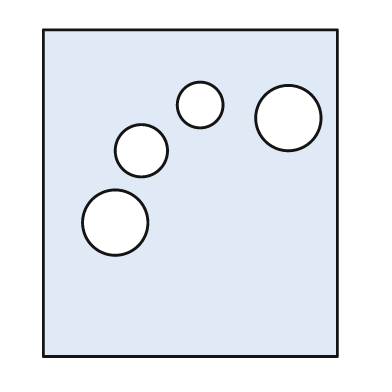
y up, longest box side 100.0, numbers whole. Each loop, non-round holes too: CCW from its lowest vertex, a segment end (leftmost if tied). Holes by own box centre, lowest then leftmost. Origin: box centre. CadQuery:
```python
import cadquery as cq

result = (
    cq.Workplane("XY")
    .moveTo(-45.0, -50.0)
    .lineTo(45.0, -50.0)
    .lineTo(45.0, 50.0)
    .lineTo(-45.0, 50.0)
    .close()
    .moveTo(-23.0, -9.0)
    .circle(10.0)
    .moveTo(-15.0, 13.0)
    .circle(8.0)
    .moveTo(30.0, 23.0)
    .circle(10.0)
    .moveTo(3.0, 27.0)
    .circle(7.0)
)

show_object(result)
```